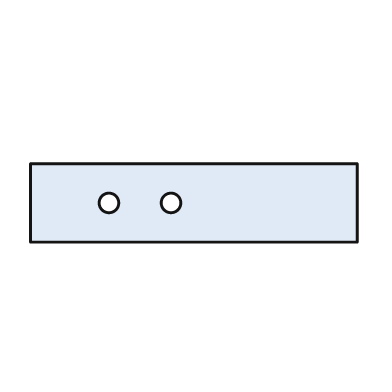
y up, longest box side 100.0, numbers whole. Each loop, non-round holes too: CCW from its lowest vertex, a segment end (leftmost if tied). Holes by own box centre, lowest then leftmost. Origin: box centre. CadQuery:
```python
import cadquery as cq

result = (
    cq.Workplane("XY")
    .moveTo(-50.0, -12.0)
    .lineTo(50.0, -12.0)
    .lineTo(50.0, 12.0)
    .lineTo(-50.0, 12.0)
    .close()
    .moveTo(-26.0, 0.0)
    .circle(3.0)
    .moveTo(-7.0, 0.0)
    .circle(3.0)
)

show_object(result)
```